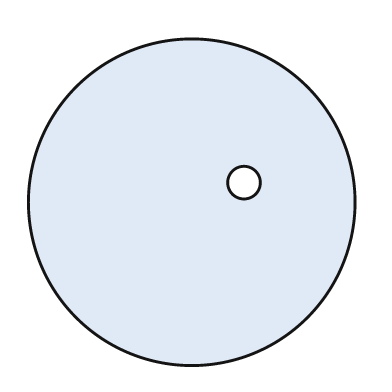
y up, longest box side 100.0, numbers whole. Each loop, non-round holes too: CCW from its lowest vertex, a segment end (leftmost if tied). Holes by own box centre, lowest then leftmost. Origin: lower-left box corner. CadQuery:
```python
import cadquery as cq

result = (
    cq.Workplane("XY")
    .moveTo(50.0, 50.0)
    .circle(50.0)
    .moveTo(66.0, 56.0)
    .circle(5.0)
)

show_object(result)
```